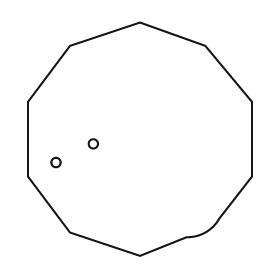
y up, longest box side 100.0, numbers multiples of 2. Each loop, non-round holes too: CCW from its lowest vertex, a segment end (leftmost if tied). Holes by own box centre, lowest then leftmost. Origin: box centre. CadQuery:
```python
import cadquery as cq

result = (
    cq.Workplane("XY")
    .moveTo(0.0, -50.0)
    .lineTo(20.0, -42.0)
    .threePointArc((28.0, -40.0), (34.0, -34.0))
    .lineTo(48.0, -16.0)
    .lineTo(48.0, 16.0)
    .lineTo(28.0, 40.0)
    .lineTo(0.0, 50.0)
    .lineTo(-30.0, 40.0)
    .lineTo(-48.0, 16.0)
    .lineTo(-48.0, -16.0)
    .lineTo(-30.0, -40.0)
    .close()
    .moveTo(-36.0, -10.0)
    .circle(2.0)
    .moveTo(-20.0, -2.0)
    .circle(2.0)
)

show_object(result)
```